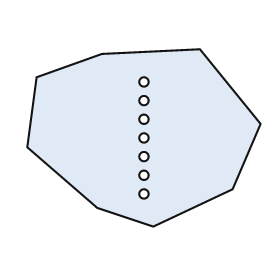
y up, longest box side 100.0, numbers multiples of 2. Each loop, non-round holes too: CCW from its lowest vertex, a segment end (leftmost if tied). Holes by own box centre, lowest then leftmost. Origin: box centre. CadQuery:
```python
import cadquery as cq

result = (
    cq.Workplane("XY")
    .moveTo(4.0, -38.0)
    .lineTo(38.0, -22.0)
    .lineTo(50.0, 6.0)
    .lineTo(24.0, 38.0)
    .lineTo(-18.0, 36.0)
    .lineTo(-46.0, 26.0)
    .lineTo(-50.0, -4.0)
    .lineTo(-20.0, -30.0)
    .close()
    .moveTo(0.0, -24.0)
    .circle(2.0)
    .moveTo(0.0, -16.0)
    .circle(2.0)
    .moveTo(0.0, -8.0)
    .circle(2.0)
    .moveTo(0.0, 0.0)
    .circle(2.0)
    .moveTo(0.0, 8.0)
    .circle(2.0)
    .moveTo(0.0, 16.0)
    .circle(2.0)
    .moveTo(0.0, 24.0)
    .circle(2.0)
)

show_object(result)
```